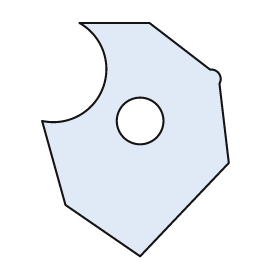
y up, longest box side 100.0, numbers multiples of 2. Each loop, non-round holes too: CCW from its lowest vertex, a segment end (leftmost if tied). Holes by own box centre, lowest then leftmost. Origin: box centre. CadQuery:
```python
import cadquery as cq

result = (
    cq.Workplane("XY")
    .moveTo(2.0, -50.0)
    .lineTo(40.0, -10.0)
    .lineTo(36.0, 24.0)
    .threePointArc((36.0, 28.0), (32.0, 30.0))
    .lineTo(6.0, 50.0)
    .lineTo(-24.0, 50.0)
    .threePointArc((-14.0, 22.0), (-40.0, 8.0))
    .lineTo(-30.0, -28.0)
    .close()
    .moveTo(2.0, 8.0)
    .circle(10.0)
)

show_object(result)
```